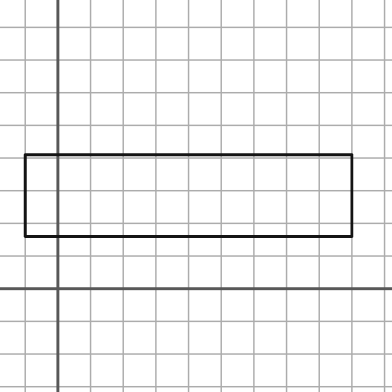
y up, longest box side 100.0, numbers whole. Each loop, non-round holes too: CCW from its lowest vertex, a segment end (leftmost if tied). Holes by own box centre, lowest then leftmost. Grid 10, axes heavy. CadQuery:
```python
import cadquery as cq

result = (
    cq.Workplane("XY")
    .moveTo(-10.0, 16.0)
    .lineTo(90.0, 16.0)
    .lineTo(90.0, 41.0)
    .lineTo(-10.0, 41.0)
    .close()
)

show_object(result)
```